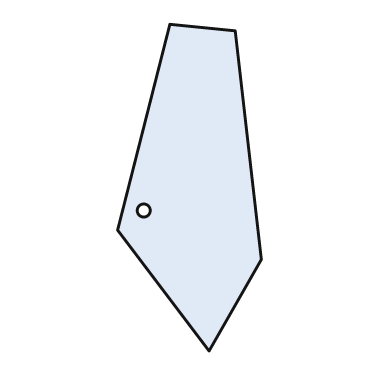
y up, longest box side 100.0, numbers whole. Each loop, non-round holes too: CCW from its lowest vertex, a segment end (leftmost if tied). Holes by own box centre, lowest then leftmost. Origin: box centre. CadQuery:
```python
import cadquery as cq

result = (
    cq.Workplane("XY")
    .moveTo(6.0, -50.0)
    .lineTo(22.0, -22.0)
    .lineTo(14.0, 48.0)
    .lineTo(-6.0, 50.0)
    .lineTo(-22.0, -13.0)
    .close()
    .moveTo(-14.0, -7.0)
    .circle(2.0)
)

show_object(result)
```